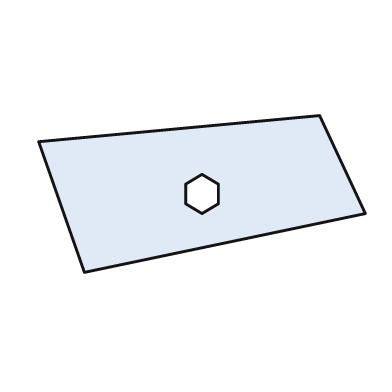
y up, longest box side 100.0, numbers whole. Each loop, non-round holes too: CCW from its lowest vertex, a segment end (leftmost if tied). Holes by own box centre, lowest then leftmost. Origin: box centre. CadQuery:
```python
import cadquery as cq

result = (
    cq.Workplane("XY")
    .moveTo(-36.0, -24.0)
    .lineTo(50.0, -6.0)
    .lineTo(36.0, 24.0)
    .lineTo(-50.0, 16.0)
    .close()
    .moveTo(0.0, -6.0)
    .lineTo(5.0, -3.0)
    .lineTo(5.0, 3.0)
    .lineTo(0.0, 6.0)
    .lineTo(-5.0, 3.0)
    .lineTo(-5.0, -3.0)
    .close()
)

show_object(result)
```